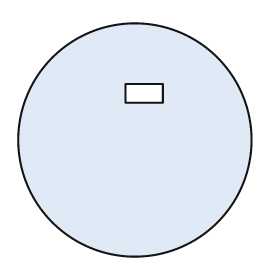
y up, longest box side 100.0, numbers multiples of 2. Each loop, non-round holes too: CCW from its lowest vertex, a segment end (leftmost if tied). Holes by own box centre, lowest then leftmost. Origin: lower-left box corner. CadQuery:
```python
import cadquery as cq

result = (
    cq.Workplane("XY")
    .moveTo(50.0, 50.0)
    .circle(50.0)
    .moveTo(46.0, 66.0)
    .lineTo(62.0, 66.0)
    .lineTo(62.0, 74.0)
    .lineTo(46.0, 74.0)
    .close()
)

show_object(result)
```